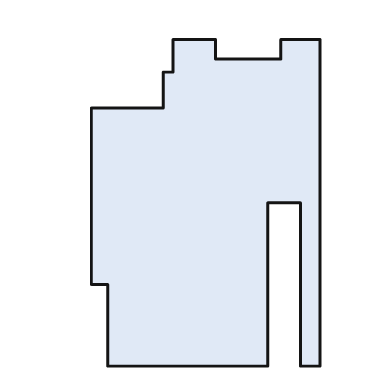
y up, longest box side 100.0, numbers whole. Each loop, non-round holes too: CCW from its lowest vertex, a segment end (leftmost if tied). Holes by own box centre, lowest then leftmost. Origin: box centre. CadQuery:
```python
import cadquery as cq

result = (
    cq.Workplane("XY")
    .moveTo(-30.0, -50.0)
    .lineTo(19.0, -50.0)
    .lineTo(19.0, 0.0)
    .lineTo(29.0, 0.0)
    .lineTo(29.0, -50.0)
    .lineTo(35.0, -50.0)
    .lineTo(35.0, 50.0)
    .lineTo(23.0, 50.0)
    .lineTo(23.0, 44.0)
    .lineTo(3.0, 44.0)
    .lineTo(3.0, 50.0)
    .lineTo(-10.0, 50.0)
    .lineTo(-10.0, 40.0)
    .lineTo(-13.0, 40.0)
    .lineTo(-13.0, 29.0)
    .lineTo(-35.0, 29.0)
    .lineTo(-35.0, -25.0)
    .lineTo(-30.0, -25.0)
    .close()
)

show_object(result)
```